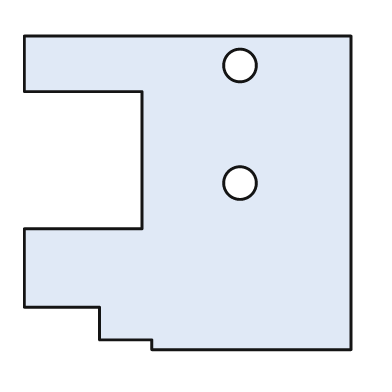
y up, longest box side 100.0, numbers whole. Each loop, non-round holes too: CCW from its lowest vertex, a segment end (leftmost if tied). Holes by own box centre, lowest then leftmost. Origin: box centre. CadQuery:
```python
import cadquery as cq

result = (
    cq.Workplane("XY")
    .moveTo(-11.0, -48.0)
    .lineTo(50.0, -48.0)
    .lineTo(50.0, 48.0)
    .lineTo(-50.0, 48.0)
    .lineTo(-50.0, 31.0)
    .lineTo(-14.0, 31.0)
    .lineTo(-14.0, -11.0)
    .lineTo(-50.0, -11.0)
    .lineTo(-50.0, -35.0)
    .lineTo(-27.0, -35.0)
    .lineTo(-27.0, -45.0)
    .lineTo(-11.0, -45.0)
    .close()
    .moveTo(16.0, 3.0)
    .circle(5.0)
    .moveTo(16.0, 39.0)
    .circle(5.0)
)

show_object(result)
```